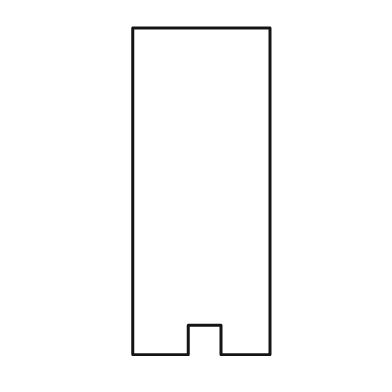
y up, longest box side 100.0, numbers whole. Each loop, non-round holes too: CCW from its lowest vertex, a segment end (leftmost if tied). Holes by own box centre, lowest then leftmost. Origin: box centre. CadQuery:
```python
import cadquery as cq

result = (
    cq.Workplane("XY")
    .moveTo(-21.0, -50.0)
    .lineTo(-4.0, -50.0)
    .lineTo(-4.0, -41.0)
    .lineTo(6.0, -41.0)
    .lineTo(6.0, -50.0)
    .lineTo(21.0, -50.0)
    .lineTo(21.0, 50.0)
    .lineTo(-21.0, 50.0)
    .close()
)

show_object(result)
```